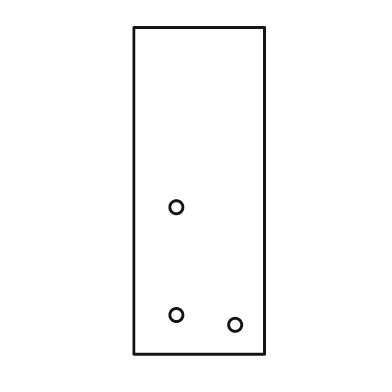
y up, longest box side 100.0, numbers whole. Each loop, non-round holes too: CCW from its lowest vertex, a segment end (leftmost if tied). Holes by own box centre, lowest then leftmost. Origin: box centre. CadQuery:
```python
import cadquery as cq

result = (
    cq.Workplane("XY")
    .moveTo(-20.0, -50.0)
    .lineTo(20.0, -50.0)
    .lineTo(20.0, 50.0)
    .lineTo(-20.0, 50.0)
    .close()
    .moveTo(11.0, -41.0)
    .circle(2.0)
    .moveTo(-7.0, -38.0)
    .circle(2.0)
    .moveTo(-7.0, -5.0)
    .circle(2.0)
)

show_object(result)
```